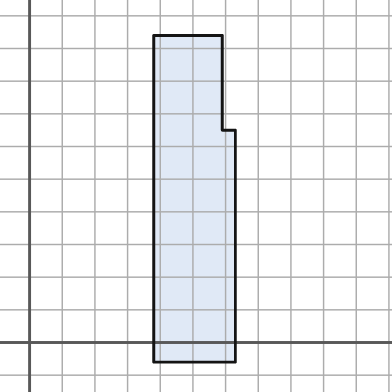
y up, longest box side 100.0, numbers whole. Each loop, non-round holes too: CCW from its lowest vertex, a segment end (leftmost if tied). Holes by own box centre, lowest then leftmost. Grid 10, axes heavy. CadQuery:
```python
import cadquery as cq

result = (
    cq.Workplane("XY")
    .moveTo(38.0, -6.0)
    .lineTo(63.0, -6.0)
    .lineTo(63.0, 65.0)
    .lineTo(59.0, 65.0)
    .lineTo(59.0, 94.0)
    .lineTo(38.0, 94.0)
    .close()
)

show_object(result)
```